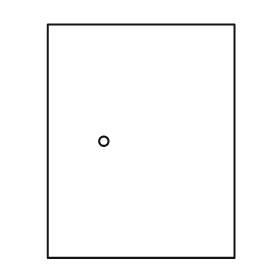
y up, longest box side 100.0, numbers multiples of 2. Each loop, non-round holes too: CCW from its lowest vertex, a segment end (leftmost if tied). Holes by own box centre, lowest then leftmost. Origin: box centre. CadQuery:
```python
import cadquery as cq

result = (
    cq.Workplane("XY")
    .moveTo(-40.0, -50.0)
    .lineTo(40.0, -50.0)
    .lineTo(40.0, 50.0)
    .lineTo(-40.0, 50.0)
    .close()
    .moveTo(-16.0, 0.0)
    .circle(2.0)
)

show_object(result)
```